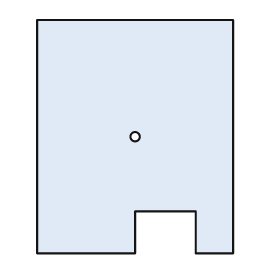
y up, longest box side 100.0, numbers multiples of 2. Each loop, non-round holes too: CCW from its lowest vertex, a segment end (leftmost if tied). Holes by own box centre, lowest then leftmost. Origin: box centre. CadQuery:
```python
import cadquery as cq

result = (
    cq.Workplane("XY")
    .moveTo(-42.0, -50.0)
    .lineTo(0.0, -50.0)
    .lineTo(0.0, -32.0)
    .lineTo(26.0, -32.0)
    .lineTo(26.0, -50.0)
    .lineTo(42.0, -50.0)
    .lineTo(42.0, 50.0)
    .lineTo(-42.0, 50.0)
    .close()
    .moveTo(0.0, 0.0)
    .circle(2.0)
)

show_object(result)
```